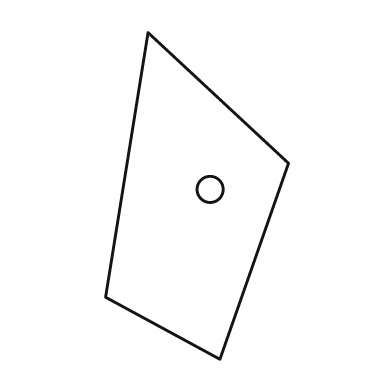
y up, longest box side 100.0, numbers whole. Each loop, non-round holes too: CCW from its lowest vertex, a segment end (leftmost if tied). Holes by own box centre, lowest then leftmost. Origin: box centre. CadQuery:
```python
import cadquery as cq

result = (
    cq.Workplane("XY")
    .moveTo(7.0, -50.0)
    .lineTo(28.0, 10.0)
    .lineTo(-15.0, 50.0)
    .lineTo(-28.0, -31.0)
    .close()
    .moveTo(4.0, 2.0)
    .circle(4.0)
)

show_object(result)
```